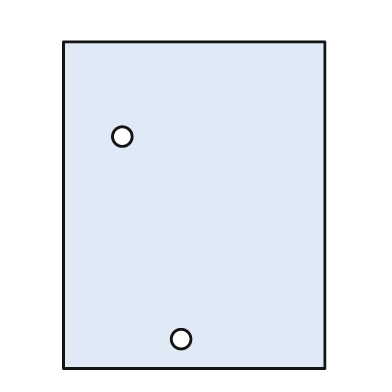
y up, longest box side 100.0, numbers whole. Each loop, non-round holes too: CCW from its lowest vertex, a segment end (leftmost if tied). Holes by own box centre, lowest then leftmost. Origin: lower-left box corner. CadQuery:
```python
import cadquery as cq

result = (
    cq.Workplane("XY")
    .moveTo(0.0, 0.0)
    .lineTo(80.0, 0.0)
    .lineTo(80.0, 100.0)
    .lineTo(0.0, 100.0)
    .close()
    .moveTo(36.0, 9.0)
    .circle(3.0)
    .moveTo(18.0, 71.0)
    .circle(3.0)
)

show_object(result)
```